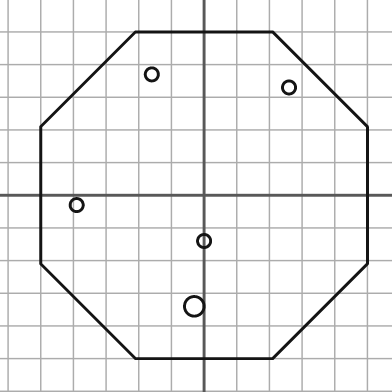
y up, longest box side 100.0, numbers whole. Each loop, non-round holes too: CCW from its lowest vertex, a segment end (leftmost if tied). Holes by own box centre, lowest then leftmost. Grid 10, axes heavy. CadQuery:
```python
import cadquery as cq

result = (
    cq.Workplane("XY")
    .moveTo(-21.0, -50.0)
    .lineTo(21.0, -50.0)
    .lineTo(50.0, -21.0)
    .lineTo(50.0, 21.0)
    .lineTo(21.0, 50.0)
    .lineTo(-21.0, 50.0)
    .lineTo(-50.0, 21.0)
    .lineTo(-50.0, -21.0)
    .close()
    .moveTo(-3.0, -34.0)
    .circle(3.0)
    .moveTo(0.0, -14.0)
    .circle(2.0)
    .moveTo(-39.0, -3.0)
    .circle(2.0)
    .moveTo(26.0, 33.0)
    .circle(2.0)
    .moveTo(-16.0, 37.0)
    .circle(2.0)
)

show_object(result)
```